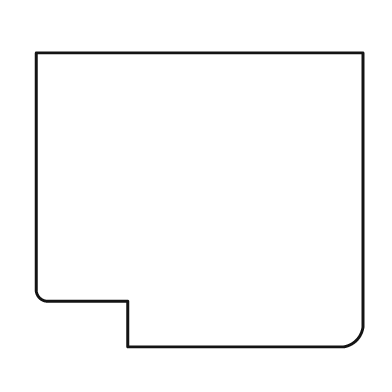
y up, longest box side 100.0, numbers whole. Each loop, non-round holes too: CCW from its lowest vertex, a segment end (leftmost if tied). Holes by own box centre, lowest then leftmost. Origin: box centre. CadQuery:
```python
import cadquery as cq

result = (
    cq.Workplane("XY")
    .moveTo(-22.0, -45.0)
    .lineTo(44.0, -45.0)
    .threePointArc((48.0, -43.0), (50.0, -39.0))
    .lineTo(50.0, 45.0)
    .lineTo(-50.0, 45.0)
    .lineTo(-50.0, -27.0)
    .threePointArc((-49.0, -30.0), (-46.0, -31.0))
    .lineTo(-22.0, -31.0)
    .close()
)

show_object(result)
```